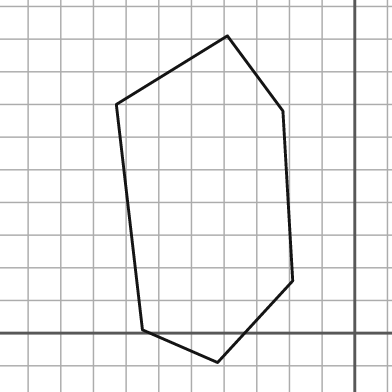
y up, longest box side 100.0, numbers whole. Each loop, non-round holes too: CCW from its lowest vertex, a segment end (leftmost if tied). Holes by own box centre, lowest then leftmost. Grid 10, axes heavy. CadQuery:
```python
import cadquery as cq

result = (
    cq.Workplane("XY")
    .moveTo(-42.0, -9.0)
    .lineTo(-19.0, 16.0)
    .lineTo(-22.0, 68.0)
    .lineTo(-39.0, 91.0)
    .lineTo(-73.0, 70.0)
    .lineTo(-65.0, 1.0)
    .close()
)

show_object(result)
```